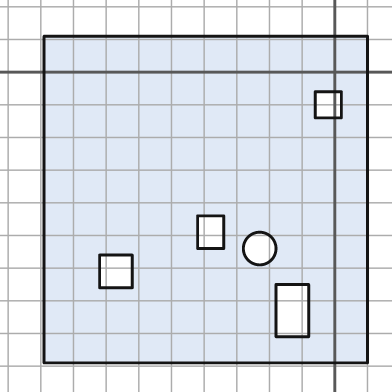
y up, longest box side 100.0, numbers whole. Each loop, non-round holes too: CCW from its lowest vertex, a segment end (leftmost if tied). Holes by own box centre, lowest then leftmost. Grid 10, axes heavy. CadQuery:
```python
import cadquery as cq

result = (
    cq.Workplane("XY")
    .moveTo(-89.0, -89.0)
    .lineTo(10.0, -89.0)
    .lineTo(10.0, 11.0)
    .lineTo(-89.0, 11.0)
    .close()
    .moveTo(-18.0, -81.0)
    .lineTo(-8.0, -81.0)
    .lineTo(-8.0, -65.0)
    .lineTo(-18.0, -65.0)
    .close()
    .moveTo(-72.0, -66.0)
    .lineTo(-62.0, -66.0)
    .lineTo(-62.0, -56.0)
    .lineTo(-72.0, -56.0)
    .close()
    .moveTo(-23.0, -54.0)
    .circle(5.0)
    .moveTo(-42.0, -54.0)
    .lineTo(-34.0, -54.0)
    .lineTo(-34.0, -44.0)
    .lineTo(-42.0, -44.0)
    .close()
    .moveTo(-6.0, -14.0)
    .lineTo(2.0, -14.0)
    .lineTo(2.0, -6.0)
    .lineTo(-6.0, -6.0)
    .close()
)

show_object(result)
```